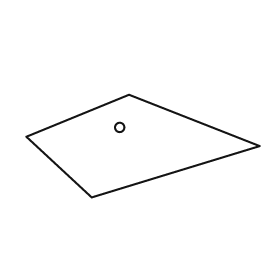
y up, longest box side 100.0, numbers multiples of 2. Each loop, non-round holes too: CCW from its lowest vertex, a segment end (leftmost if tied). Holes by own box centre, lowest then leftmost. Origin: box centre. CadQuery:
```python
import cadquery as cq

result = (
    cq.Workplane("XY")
    .moveTo(-22.0, -22.0)
    .lineTo(50.0, 0.0)
    .lineTo(-6.0, 22.0)
    .lineTo(-50.0, 4.0)
    .close()
    .moveTo(-10.0, 8.0)
    .circle(2.0)
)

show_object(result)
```